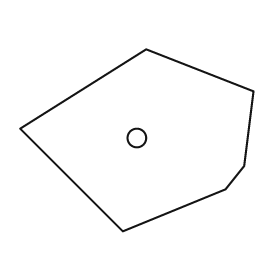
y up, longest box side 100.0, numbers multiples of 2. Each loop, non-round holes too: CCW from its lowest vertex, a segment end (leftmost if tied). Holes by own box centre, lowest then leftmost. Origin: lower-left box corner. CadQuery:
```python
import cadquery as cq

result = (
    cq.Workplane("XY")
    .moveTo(44.0, 0.0)
    .lineTo(88.0, 18.0)
    .lineTo(96.0, 28.0)
    .lineTo(100.0, 60.0)
    .lineTo(54.0, 78.0)
    .lineTo(0.0, 44.0)
    .close()
    .moveTo(50.0, 40.0)
    .circle(4.0)
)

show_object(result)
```